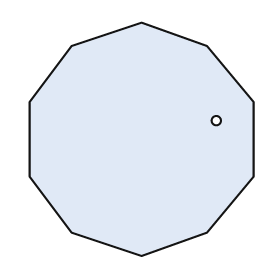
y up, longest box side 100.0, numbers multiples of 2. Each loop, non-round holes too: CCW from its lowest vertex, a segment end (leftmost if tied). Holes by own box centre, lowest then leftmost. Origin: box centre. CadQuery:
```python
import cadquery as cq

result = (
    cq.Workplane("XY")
    .moveTo(0.0, -50.0)
    .lineTo(28.0, -40.0)
    .lineTo(48.0, -16.0)
    .lineTo(48.0, 16.0)
    .lineTo(28.0, 40.0)
    .lineTo(0.0, 50.0)
    .lineTo(-30.0, 40.0)
    .lineTo(-48.0, 16.0)
    .lineTo(-48.0, -16.0)
    .lineTo(-30.0, -40.0)
    .close()
    .moveTo(32.0, 8.0)
    .circle(2.0)
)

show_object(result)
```